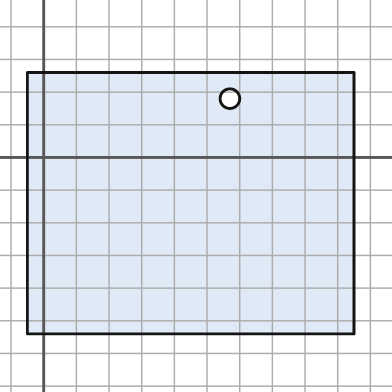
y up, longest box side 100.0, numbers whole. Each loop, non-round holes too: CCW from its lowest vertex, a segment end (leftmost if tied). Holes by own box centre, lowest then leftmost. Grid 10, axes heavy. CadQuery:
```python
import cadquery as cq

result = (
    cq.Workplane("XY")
    .moveTo(-5.0, -54.0)
    .lineTo(95.0, -54.0)
    .lineTo(95.0, 26.0)
    .lineTo(-5.0, 26.0)
    .close()
    .moveTo(57.0, 18.0)
    .circle(3.0)
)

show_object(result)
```